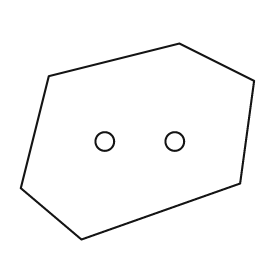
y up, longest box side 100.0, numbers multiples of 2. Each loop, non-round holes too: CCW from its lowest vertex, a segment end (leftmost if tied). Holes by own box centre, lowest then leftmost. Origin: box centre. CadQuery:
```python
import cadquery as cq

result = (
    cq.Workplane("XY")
    .moveTo(-24.0, -42.0)
    .lineTo(44.0, -18.0)
    .lineTo(50.0, 26.0)
    .lineTo(18.0, 42.0)
    .lineTo(-38.0, 28.0)
    .lineTo(-50.0, -20.0)
    .close()
    .moveTo(-14.0, 0.0)
    .circle(4.0)
    .moveTo(16.0, 0.0)
    .circle(4.0)
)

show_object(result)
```